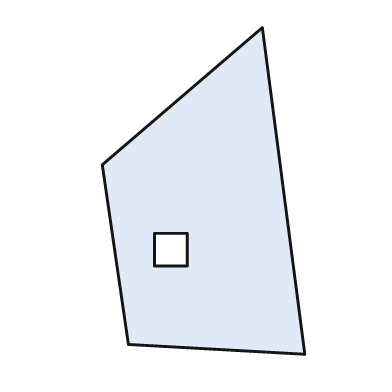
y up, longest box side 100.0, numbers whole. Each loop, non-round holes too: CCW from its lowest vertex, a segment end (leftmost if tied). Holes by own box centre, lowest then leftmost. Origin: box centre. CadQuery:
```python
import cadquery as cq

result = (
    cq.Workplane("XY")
    .moveTo(31.0, -50.0)
    .lineTo(18.0, 50.0)
    .lineTo(-31.0, 8.0)
    .lineTo(-23.0, -47.0)
    .close()
    .moveTo(-15.0, -23.0)
    .lineTo(-5.0, -23.0)
    .lineTo(-5.0, -13.0)
    .lineTo(-15.0, -13.0)
    .close()
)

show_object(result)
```